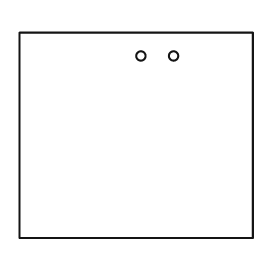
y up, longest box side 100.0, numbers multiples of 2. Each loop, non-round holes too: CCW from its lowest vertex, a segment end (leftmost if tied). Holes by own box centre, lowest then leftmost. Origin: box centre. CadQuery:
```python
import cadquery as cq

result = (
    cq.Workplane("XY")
    .moveTo(-50.0, -44.0)
    .lineTo(50.0, -44.0)
    .lineTo(50.0, 44.0)
    .lineTo(-50.0, 44.0)
    .close()
    .moveTo(2.0, 34.0)
    .circle(2.0)
    .moveTo(16.0, 34.0)
    .circle(2.0)
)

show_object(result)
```